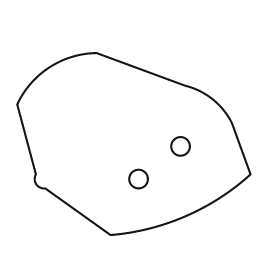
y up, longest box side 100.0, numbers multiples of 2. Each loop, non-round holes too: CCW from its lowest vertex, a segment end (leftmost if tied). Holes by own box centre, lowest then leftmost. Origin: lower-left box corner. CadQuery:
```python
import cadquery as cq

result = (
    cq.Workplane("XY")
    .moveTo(40.0, 0.0)
    .threePointArc((72.0, 8.0), (100.0, 26.0))
    .lineTo(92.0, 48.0)
    .threePointArc((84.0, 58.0), (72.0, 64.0))
    .lineTo(34.0, 78.0)
    .threePointArc((14.0, 72.0), (0.0, 56.0))
    .lineTo(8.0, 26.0)
    .threePointArc((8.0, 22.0), (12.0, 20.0))
    .close()
    .moveTo(52.0, 24.0)
    .circle(4.0)
    .moveTo(70.0, 38.0)
    .circle(4.0)
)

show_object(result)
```